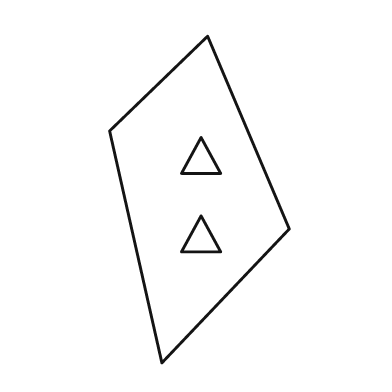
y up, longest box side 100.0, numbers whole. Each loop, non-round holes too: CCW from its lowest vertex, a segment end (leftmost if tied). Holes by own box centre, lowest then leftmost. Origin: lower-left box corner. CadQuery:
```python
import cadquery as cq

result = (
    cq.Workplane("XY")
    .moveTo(16.0, 0.0)
    .lineTo(55.0, 41.0)
    .lineTo(30.0, 100.0)
    .lineTo(0.0, 71.0)
    .close()
    .moveTo(22.0, 34.0)
    .lineTo(34.0, 34.0)
    .lineTo(28.0, 45.0)
    .close()
    .moveTo(22.0, 58.0)
    .lineTo(34.0, 58.0)
    .lineTo(28.0, 69.0)
    .close()
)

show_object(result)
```